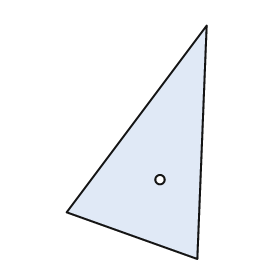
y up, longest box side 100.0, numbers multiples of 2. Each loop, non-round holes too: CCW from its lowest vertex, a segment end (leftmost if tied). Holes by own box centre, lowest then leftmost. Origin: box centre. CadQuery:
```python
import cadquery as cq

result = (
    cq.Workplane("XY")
    .moveTo(26.0, -50.0)
    .lineTo(30.0, 50.0)
    .lineTo(-30.0, -30.0)
    .close()
    .moveTo(10.0, -16.0)
    .circle(2.0)
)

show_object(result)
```